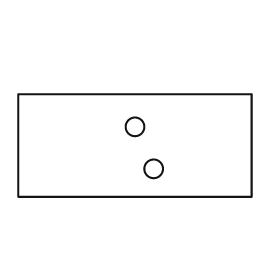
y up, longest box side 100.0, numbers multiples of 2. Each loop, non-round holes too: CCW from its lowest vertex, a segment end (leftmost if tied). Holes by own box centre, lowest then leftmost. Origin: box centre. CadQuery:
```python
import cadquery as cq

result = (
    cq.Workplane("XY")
    .moveTo(-50.0, -22.0)
    .lineTo(50.0, -22.0)
    .lineTo(50.0, 22.0)
    .lineTo(-50.0, 22.0)
    .close()
    .moveTo(8.0, -10.0)
    .circle(4.0)
    .moveTo(0.0, 8.0)
    .circle(4.0)
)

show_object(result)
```